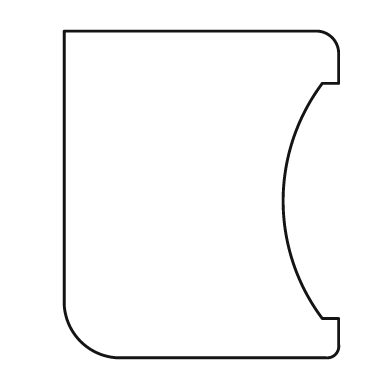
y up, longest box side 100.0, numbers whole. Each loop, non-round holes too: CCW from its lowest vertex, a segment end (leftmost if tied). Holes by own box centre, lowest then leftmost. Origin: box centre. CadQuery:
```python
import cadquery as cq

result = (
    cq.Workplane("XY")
    .moveTo(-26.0, -50.0)
    .lineTo(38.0, -50.0)
    .threePointArc((41.0, -49.0), (42.0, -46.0))
    .lineTo(42.0, -38.0)
    .lineTo(37.0, -38.0)
    .threePointArc((25.0, -2.0), (37.0, 34.0))
    .lineTo(42.0, 34.0)
    .lineTo(42.0, 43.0)
    .threePointArc((40.0, 48.0), (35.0, 50.0))
    .lineTo(-42.0, 50.0)
    .lineTo(-42.0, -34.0)
    .threePointArc((-37.0, -45.0), (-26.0, -50.0))
    .close()
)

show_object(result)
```